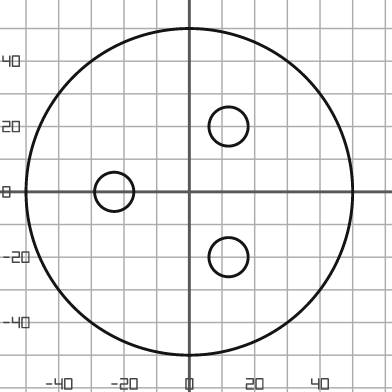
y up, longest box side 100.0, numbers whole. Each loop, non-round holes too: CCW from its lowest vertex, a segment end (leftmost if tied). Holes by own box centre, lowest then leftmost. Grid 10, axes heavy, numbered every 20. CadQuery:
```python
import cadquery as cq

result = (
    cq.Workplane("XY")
    .moveTo(0.0, 0.0)
    .circle(50.0)
    .moveTo(12.0, -20.0)
    .circle(6.0)
    .moveTo(-23.0, 0.0)
    .circle(6.0)
    .moveTo(12.0, 20.0)
    .circle(6.0)
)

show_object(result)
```